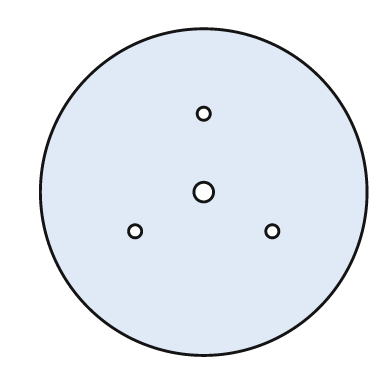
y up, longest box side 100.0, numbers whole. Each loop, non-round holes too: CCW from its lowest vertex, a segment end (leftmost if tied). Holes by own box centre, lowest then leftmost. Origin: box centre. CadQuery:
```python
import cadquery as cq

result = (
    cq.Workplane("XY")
    .moveTo(0.0, 0.0)
    .circle(50.0)
    .moveTo(-21.0, -12.0)
    .circle(2.0)
    .moveTo(21.0, -12.0)
    .circle(2.0)
    .moveTo(0.0, 0.0)
    .circle(3.0)
    .moveTo(0.0, 24.0)
    .circle(2.0)
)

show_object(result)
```